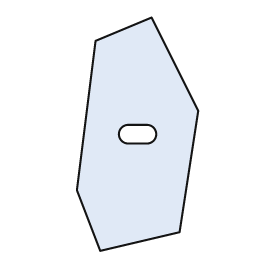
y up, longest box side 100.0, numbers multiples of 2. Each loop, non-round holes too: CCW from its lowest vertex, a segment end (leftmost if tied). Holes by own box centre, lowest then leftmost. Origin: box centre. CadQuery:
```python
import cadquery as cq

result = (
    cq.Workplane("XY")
    .moveTo(-16.0, -50.0)
    .lineTo(18.0, -42.0)
    .lineTo(26.0, 10.0)
    .lineTo(6.0, 50.0)
    .lineTo(-18.0, 40.0)
    .lineTo(-26.0, -24.0)
    .close()
    .moveTo(-4.0, -4.0)
    .lineTo(4.0, -4.0)
    .threePointArc((8.0, 0.0), (4.0, 4.0))
    .lineTo(-4.0, 4.0)
    .threePointArc((-8.0, 0.0), (-4.0, -4.0))
    .close()
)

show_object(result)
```